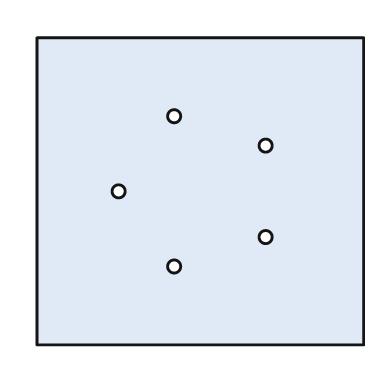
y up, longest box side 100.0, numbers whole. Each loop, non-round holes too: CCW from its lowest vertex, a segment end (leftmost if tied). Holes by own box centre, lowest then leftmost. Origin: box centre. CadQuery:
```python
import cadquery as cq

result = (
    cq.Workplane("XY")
    .moveTo(-50.0, -47.0)
    .lineTo(50.0, -47.0)
    .lineTo(50.0, 47.0)
    .lineTo(-50.0, 47.0)
    .close()
    .moveTo(-8.0, -23.0)
    .circle(2.0)
    .moveTo(20.0, -14.0)
    .circle(2.0)
    .moveTo(-25.0, 0.0)
    .circle(2.0)
    .moveTo(20.0, 14.0)
    .circle(2.0)
    .moveTo(-8.0, 23.0)
    .circle(2.0)
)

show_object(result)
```